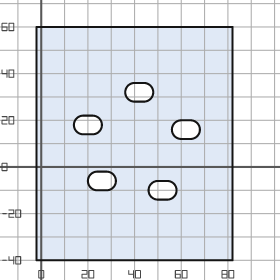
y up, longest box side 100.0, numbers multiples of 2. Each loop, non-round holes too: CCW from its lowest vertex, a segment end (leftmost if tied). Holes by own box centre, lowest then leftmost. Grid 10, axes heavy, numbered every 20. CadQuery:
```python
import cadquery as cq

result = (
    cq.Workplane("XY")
    .moveTo(-2.0, -40.0)
    .lineTo(82.0, -40.0)
    .lineTo(82.0, 60.0)
    .lineTo(-2.0, 60.0)
    .close()
    .moveTo(50.0, -14.0)
    .lineTo(54.0, -14.0)
    .threePointArc((58.0, -10.0), (54.0, -6.0))
    .lineTo(50.0, -6.0)
    .threePointArc((46.0, -10.0), (50.0, -14.0))
    .close()
    .moveTo(24.0, -10.0)
    .lineTo(28.0, -10.0)
    .threePointArc((32.0, -6.0), (28.0, -2.0))
    .lineTo(24.0, -2.0)
    .threePointArc((20.0, -6.0), (24.0, -10.0))
    .close()
    .moveTo(60.0, 12.0)
    .lineTo(64.0, 12.0)
    .threePointArc((68.0, 16.0), (64.0, 20.0))
    .lineTo(60.0, 20.0)
    .threePointArc((56.0, 16.0), (60.0, 12.0))
    .close()
    .moveTo(18.0, 14.0)
    .lineTo(22.0, 14.0)
    .threePointArc((26.0, 18.0), (22.0, 22.0))
    .lineTo(18.0, 22.0)
    .threePointArc((14.0, 18.0), (18.0, 14.0))
    .close()
    .moveTo(40.0, 28.0)
    .lineTo(44.0, 28.0)
    .threePointArc((48.0, 32.0), (44.0, 36.0))
    .lineTo(40.0, 36.0)
    .threePointArc((36.0, 32.0), (40.0, 28.0))
    .close()
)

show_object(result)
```